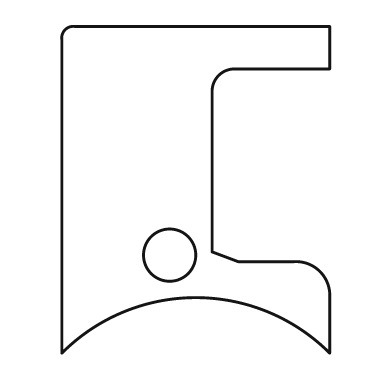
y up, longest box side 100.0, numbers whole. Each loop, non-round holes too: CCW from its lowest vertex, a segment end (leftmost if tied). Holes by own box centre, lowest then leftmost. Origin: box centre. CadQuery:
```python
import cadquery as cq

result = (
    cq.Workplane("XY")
    .moveTo(-41.0, -50.0)
    .threePointArc((0.0, -33.0), (41.0, -50.0))
    .lineTo(41.0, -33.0)
    .threePointArc((38.0, -25.0), (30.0, -22.0))
    .lineTo(13.0, -22.0)
    .lineTo(5.0, -19.0)
    .lineTo(5.0, 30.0)
    .threePointArc((7.0, 35.0), (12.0, 37.0))
    .lineTo(41.0, 37.0)
    .lineTo(41.0, 50.0)
    .lineTo(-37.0, 50.0)
    .threePointArc((-40.0, 49.0), (-41.0, 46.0))
    .close()
    .moveTo(-8.0, -20.0)
    .circle(8.0)
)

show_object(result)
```